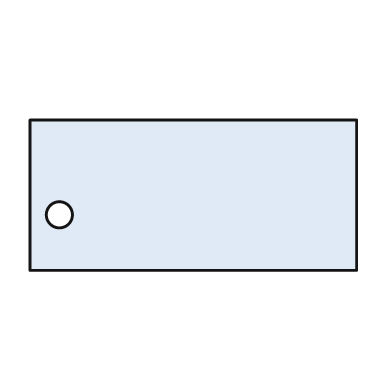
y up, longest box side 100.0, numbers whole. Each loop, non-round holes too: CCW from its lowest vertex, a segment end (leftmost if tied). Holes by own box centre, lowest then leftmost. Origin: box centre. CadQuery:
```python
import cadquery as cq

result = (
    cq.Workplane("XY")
    .moveTo(-50.0, -23.0)
    .lineTo(50.0, -23.0)
    .lineTo(50.0, 23.0)
    .lineTo(-50.0, 23.0)
    .close()
    .moveTo(-41.0, -6.0)
    .circle(4.0)
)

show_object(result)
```